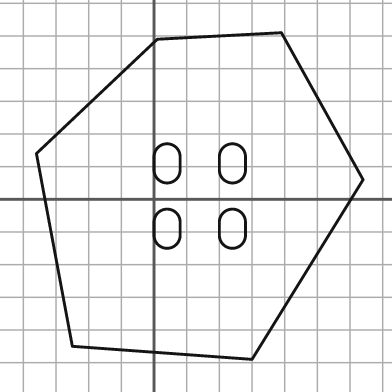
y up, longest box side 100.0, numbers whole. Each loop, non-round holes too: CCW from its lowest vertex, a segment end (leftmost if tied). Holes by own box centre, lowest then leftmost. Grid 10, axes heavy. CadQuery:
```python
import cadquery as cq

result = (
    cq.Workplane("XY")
    .moveTo(30.0, -49.0)
    .lineTo(64.0, 6.0)
    .lineTo(39.0, 51.0)
    .lineTo(1.0, 49.0)
    .lineTo(-36.0, 14.0)
    .lineTo(-25.0, -45.0)
    .close()
    .moveTo(0.0, -11.0)
    .threePointArc((4.0, -15.0), (8.0, -11.0))
    .lineTo(8.0, -7.0)
    .threePointArc((4.0, -3.0), (0.0, -7.0))
    .close()
    .moveTo(20.0, -11.0)
    .threePointArc((24.0, -15.0), (28.0, -11.0))
    .lineTo(28.0, -7.0)
    .threePointArc((24.0, -3.0), (20.0, -7.0))
    .close()
    .moveTo(0.0, 9.0)
    .threePointArc((4.0, 5.0), (8.0, 9.0))
    .lineTo(8.0, 13.0)
    .threePointArc((4.0, 17.0), (0.0, 13.0))
    .close()
    .moveTo(20.0, 9.0)
    .threePointArc((24.0, 5.0), (28.0, 9.0))
    .lineTo(28.0, 13.0)
    .threePointArc((24.0, 17.0), (20.0, 13.0))
    .close()
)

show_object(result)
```